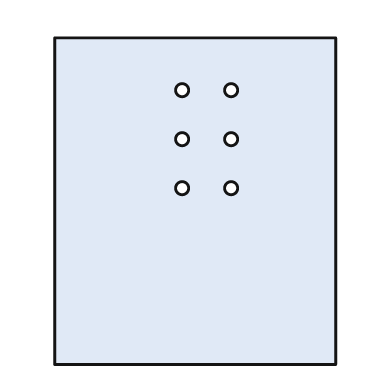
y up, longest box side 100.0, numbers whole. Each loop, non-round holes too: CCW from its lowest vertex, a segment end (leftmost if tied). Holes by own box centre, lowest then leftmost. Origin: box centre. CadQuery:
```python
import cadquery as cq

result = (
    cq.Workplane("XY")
    .moveTo(-43.0, -50.0)
    .lineTo(43.0, -50.0)
    .lineTo(43.0, 50.0)
    .lineTo(-43.0, 50.0)
    .close()
    .moveTo(-4.0, 4.0)
    .circle(2.0)
    .moveTo(11.0, 4.0)
    .circle(2.0)
    .moveTo(-4.0, 19.0)
    .circle(2.0)
    .moveTo(11.0, 19.0)
    .circle(2.0)
    .moveTo(-4.0, 34.0)
    .circle(2.0)
    .moveTo(11.0, 34.0)
    .circle(2.0)
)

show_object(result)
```